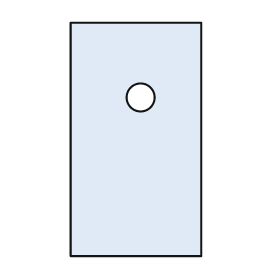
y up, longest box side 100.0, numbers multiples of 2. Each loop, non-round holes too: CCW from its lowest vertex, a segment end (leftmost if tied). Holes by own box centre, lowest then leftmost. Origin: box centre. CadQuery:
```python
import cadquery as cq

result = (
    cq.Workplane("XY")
    .moveTo(-28.0, -50.0)
    .lineTo(28.0, -50.0)
    .lineTo(28.0, 50.0)
    .lineTo(-28.0, 50.0)
    .close()
    .moveTo(2.0, 18.0)
    .circle(6.0)
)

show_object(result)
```